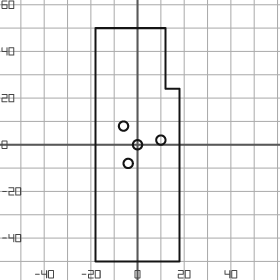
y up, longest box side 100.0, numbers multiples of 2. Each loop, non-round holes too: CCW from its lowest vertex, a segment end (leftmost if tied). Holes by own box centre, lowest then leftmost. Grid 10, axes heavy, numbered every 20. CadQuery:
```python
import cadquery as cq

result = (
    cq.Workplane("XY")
    .moveTo(-18.0, -50.0)
    .lineTo(18.0, -50.0)
    .lineTo(18.0, 24.0)
    .lineTo(12.0, 24.0)
    .lineTo(12.0, 50.0)
    .lineTo(-18.0, 50.0)
    .close()
    .moveTo(-4.0, -8.0)
    .circle(2.0)
    .moveTo(0.0, 0.0)
    .circle(2.0)
    .moveTo(10.0, 2.0)
    .circle(2.0)
    .moveTo(-6.0, 8.0)
    .circle(2.0)
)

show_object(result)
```